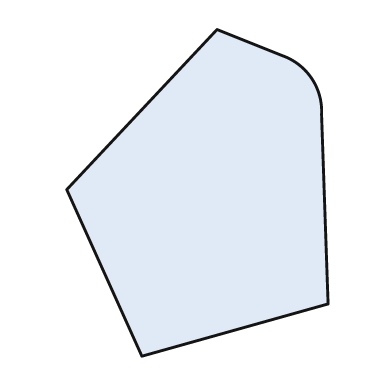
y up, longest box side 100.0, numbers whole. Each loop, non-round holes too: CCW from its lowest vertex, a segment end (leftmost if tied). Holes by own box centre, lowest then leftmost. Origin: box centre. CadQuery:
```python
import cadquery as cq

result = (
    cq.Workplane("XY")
    .moveTo(-17.0, -50.0)
    .lineTo(40.0, -34.0)
    .lineTo(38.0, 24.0)
    .threePointArc((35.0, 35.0), (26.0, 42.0))
    .lineTo(6.0, 50.0)
    .lineTo(-40.0, 1.0)
    .close()
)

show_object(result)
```